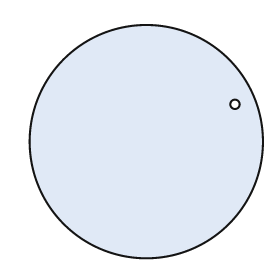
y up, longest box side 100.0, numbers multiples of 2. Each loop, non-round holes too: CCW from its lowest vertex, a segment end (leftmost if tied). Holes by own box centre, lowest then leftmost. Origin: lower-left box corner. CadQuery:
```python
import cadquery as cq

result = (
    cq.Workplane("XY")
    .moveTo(50.0, 50.0)
    .circle(50.0)
    .moveTo(88.0, 66.0)
    .circle(2.0)
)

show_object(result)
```